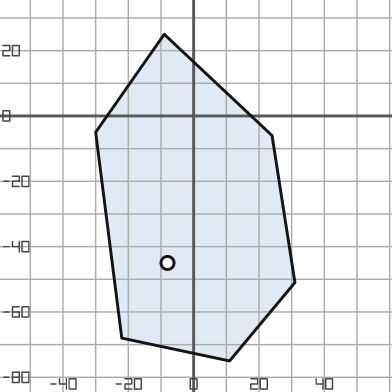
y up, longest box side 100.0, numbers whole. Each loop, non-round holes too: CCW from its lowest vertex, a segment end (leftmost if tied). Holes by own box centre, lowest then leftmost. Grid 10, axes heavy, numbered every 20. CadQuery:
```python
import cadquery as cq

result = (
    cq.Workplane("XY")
    .moveTo(11.0, -75.0)
    .lineTo(31.0, -51.0)
    .lineTo(24.0, -6.0)
    .lineTo(-9.0, 25.0)
    .lineTo(-30.0, -5.0)
    .lineTo(-22.0, -68.0)
    .close()
    .moveTo(-8.0, -45.0)
    .circle(2.0)
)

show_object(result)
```